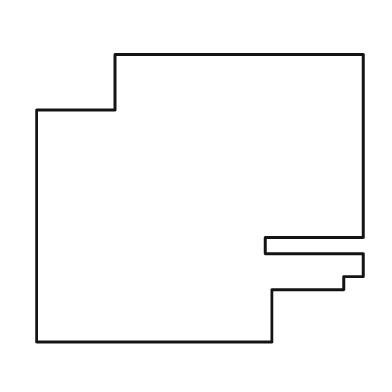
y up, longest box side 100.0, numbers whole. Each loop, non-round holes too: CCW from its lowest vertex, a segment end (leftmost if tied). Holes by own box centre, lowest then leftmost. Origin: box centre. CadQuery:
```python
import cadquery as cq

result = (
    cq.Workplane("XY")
    .moveTo(-50.0, -44.0)
    .lineTo(22.0, -44.0)
    .lineTo(22.0, -28.0)
    .lineTo(44.0, -28.0)
    .lineTo(44.0, -24.0)
    .lineTo(50.0, -24.0)
    .lineTo(50.0, -17.0)
    .lineTo(20.0, -17.0)
    .lineTo(20.0, -12.0)
    .lineTo(50.0, -12.0)
    .lineTo(50.0, 44.0)
    .lineTo(-26.0, 44.0)
    .lineTo(-26.0, 27.0)
    .lineTo(-50.0, 27.0)
    .close()
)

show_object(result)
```